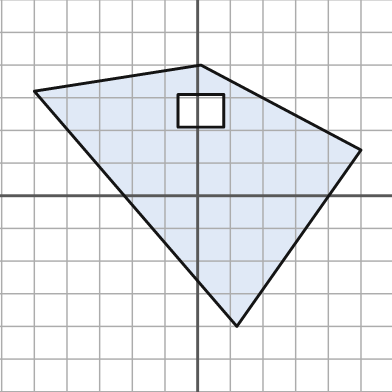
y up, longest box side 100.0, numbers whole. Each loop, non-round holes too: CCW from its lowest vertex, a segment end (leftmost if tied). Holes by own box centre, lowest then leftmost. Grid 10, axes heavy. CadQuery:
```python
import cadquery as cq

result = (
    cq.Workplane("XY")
    .moveTo(12.0, -40.0)
    .lineTo(50.0, 14.0)
    .lineTo(1.0, 40.0)
    .lineTo(-50.0, 32.0)
    .close()
    .moveTo(-6.0, 21.0)
    .lineTo(8.0, 21.0)
    .lineTo(8.0, 31.0)
    .lineTo(-6.0, 31.0)
    .close()
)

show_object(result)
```